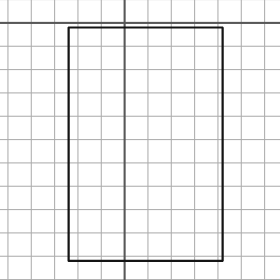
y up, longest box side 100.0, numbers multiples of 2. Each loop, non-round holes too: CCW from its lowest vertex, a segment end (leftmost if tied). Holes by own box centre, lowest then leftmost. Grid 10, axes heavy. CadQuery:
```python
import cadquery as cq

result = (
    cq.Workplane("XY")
    .moveTo(-24.0, -102.0)
    .lineTo(42.0, -102.0)
    .lineTo(42.0, -2.0)
    .lineTo(-24.0, -2.0)
    .close()
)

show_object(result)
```